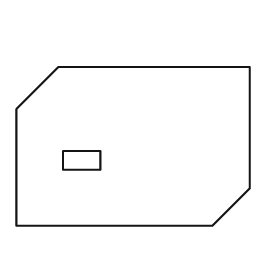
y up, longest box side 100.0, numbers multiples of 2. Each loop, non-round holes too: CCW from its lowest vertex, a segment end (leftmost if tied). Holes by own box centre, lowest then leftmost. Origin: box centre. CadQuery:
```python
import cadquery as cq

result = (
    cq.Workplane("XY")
    .moveTo(-50.0, -34.0)
    .lineTo(34.0, -34.0)
    .lineTo(50.0, -18.0)
    .lineTo(50.0, 34.0)
    .lineTo(-32.0, 34.0)
    .lineTo(-50.0, 16.0)
    .close()
    .moveTo(-30.0, -10.0)
    .lineTo(-14.0, -10.0)
    .lineTo(-14.0, -2.0)
    .lineTo(-30.0, -2.0)
    .close()
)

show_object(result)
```